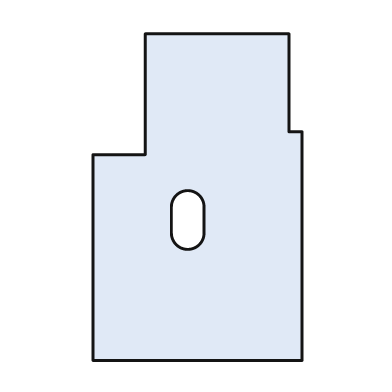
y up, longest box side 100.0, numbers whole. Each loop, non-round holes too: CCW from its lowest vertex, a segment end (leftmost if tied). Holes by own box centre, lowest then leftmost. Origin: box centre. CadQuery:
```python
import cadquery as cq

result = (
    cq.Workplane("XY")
    .moveTo(-32.0, -50.0)
    .lineTo(32.0, -50.0)
    .lineTo(32.0, 20.0)
    .lineTo(28.0, 20.0)
    .lineTo(28.0, 50.0)
    .lineTo(-16.0, 50.0)
    .lineTo(-16.0, 13.0)
    .lineTo(-32.0, 13.0)
    .close()
    .moveTo(-8.0, -11.0)
    .threePointArc((-3.0, -16.0), (2.0, -11.0))
    .lineTo(2.0, -3.0)
    .threePointArc((-3.0, 2.0), (-8.0, -3.0))
    .close()
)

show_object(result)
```